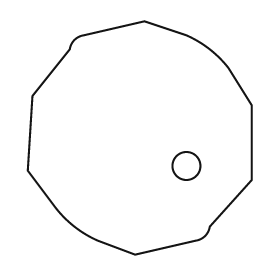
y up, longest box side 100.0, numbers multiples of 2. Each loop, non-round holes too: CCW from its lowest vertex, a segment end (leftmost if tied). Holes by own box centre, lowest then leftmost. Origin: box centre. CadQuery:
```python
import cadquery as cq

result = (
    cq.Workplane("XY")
    .moveTo(-2.0, -50.0)
    .lineTo(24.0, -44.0)
    .threePointArc((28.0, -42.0), (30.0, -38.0))
    .lineTo(48.0, -18.0)
    .lineTo(48.0, 14.0)
    .lineTo(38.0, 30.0)
    .threePointArc((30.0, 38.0), (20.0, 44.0))
    .lineTo(2.0, 50.0)
    .lineTo(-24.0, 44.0)
    .threePointArc((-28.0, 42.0), (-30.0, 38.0))
    .lineTo(-46.0, 18.0)
    .lineTo(-48.0, -14.0)
    .lineTo(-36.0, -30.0)
    .threePointArc((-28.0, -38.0), (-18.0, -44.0))
    .close()
    .moveTo(20.0, -12.0)
    .circle(6.0)
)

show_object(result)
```